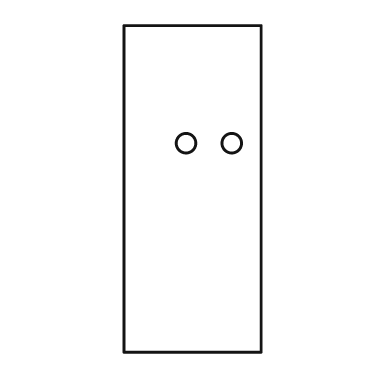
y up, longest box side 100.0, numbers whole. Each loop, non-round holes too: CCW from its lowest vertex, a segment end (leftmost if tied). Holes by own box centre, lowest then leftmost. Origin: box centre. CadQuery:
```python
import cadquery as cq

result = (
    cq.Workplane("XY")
    .moveTo(-21.0, -50.0)
    .lineTo(21.0, -50.0)
    .lineTo(21.0, 50.0)
    .lineTo(-21.0, 50.0)
    .close()
    .moveTo(-2.0, 14.0)
    .circle(3.0)
    .moveTo(12.0, 14.0)
    .circle(3.0)
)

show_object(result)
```